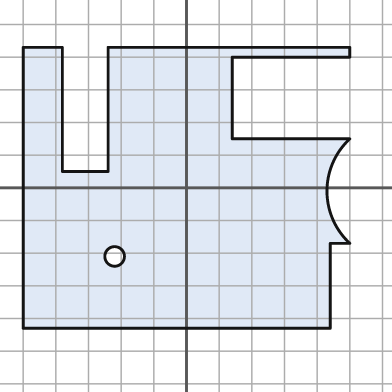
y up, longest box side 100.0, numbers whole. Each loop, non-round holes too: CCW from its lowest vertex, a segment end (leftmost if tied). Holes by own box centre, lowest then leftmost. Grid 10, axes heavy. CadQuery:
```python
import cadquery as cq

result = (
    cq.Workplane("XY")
    .moveTo(-50.0, -43.0)
    .lineTo(44.0, -43.0)
    .lineTo(44.0, -17.0)
    .lineTo(50.0, -17.0)
    .threePointArc((43.0, -1.0), (50.0, 15.0))
    .lineTo(14.0, 15.0)
    .lineTo(14.0, 40.0)
    .lineTo(50.0, 40.0)
    .lineTo(50.0, 43.0)
    .lineTo(-24.0, 43.0)
    .lineTo(-24.0, 5.0)
    .lineTo(-38.0, 5.0)
    .lineTo(-38.0, 43.0)
    .lineTo(-50.0, 43.0)
    .close()
    .moveTo(-22.0, -21.0)
    .circle(3.0)
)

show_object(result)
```